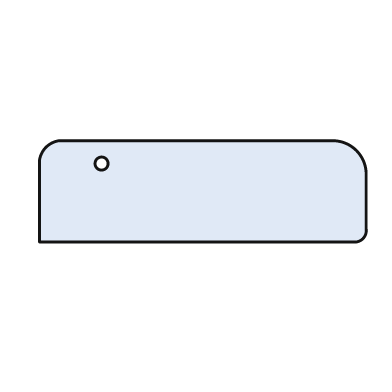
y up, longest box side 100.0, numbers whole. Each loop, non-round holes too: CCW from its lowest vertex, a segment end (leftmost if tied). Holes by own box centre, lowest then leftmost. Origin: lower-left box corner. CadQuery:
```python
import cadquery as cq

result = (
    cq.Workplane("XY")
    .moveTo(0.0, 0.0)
    .lineTo(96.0, 0.0)
    .threePointArc((99.0, 1.0), (100.0, 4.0))
    .lineTo(100.0, 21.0)
    .threePointArc((97.0, 28.0), (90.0, 31.0))
    .lineTo(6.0, 31.0)
    .threePointArc((2.0, 29.0), (0.0, 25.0))
    .close()
    .moveTo(19.0, 24.0)
    .circle(2.0)
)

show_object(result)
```